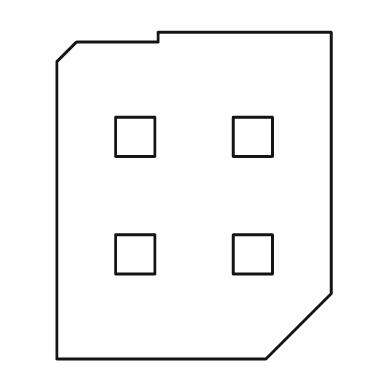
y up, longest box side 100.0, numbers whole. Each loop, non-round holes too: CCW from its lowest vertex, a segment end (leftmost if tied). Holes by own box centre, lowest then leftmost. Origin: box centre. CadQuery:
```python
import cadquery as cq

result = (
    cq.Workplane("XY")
    .moveTo(-42.0, -50.0)
    .lineTo(22.0, -50.0)
    .lineTo(42.0, -30.0)
    .lineTo(42.0, 50.0)
    .lineTo(-11.0, 50.0)
    .lineTo(-11.0, 47.0)
    .lineTo(-36.0, 47.0)
    .lineTo(-42.0, 41.0)
    .close()
    .moveTo(-24.0, -24.0)
    .lineTo(-12.0, -24.0)
    .lineTo(-12.0, -12.0)
    .lineTo(-24.0, -12.0)
    .close()
    .moveTo(12.0, -24.0)
    .lineTo(24.0, -24.0)
    .lineTo(24.0, -12.0)
    .lineTo(12.0, -12.0)
    .close()
    .moveTo(-24.0, 12.0)
    .lineTo(-12.0, 12.0)
    .lineTo(-12.0, 24.0)
    .lineTo(-24.0, 24.0)
    .close()
    .moveTo(12.0, 12.0)
    .lineTo(24.0, 12.0)
    .lineTo(24.0, 24.0)
    .lineTo(12.0, 24.0)
    .close()
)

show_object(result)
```